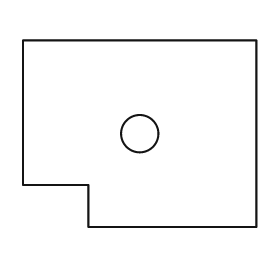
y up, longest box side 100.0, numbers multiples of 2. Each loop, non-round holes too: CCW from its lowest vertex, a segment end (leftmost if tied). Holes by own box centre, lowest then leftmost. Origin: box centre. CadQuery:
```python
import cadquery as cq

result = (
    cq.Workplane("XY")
    .moveTo(-22.0, -40.0)
    .lineTo(50.0, -40.0)
    .lineTo(50.0, 40.0)
    .lineTo(-50.0, 40.0)
    .lineTo(-50.0, -22.0)
    .lineTo(-22.0, -22.0)
    .close()
    .moveTo(0.0, 0.0)
    .circle(8.0)
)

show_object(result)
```